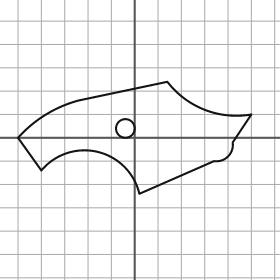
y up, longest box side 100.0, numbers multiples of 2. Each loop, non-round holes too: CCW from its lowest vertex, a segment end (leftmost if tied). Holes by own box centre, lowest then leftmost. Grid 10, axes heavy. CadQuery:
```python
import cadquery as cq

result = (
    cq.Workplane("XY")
    .moveTo(2.0, -24.0)
    .lineTo(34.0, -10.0)
    .threePointArc((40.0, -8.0), (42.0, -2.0))
    .lineTo(50.0, 10.0)
    .threePointArc((30.0, 12.0), (14.0, 24.0))
    .lineTo(-24.0, 16.0)
    .threePointArc((-38.0, 10.0), (-50.0, 0.0))
    .lineTo(-40.0, -14.0)
    .threePointArc((-16.0, -6.0), (2.0, -24.0))
    .close()
    .moveTo(-4.0, 4.0)
    .circle(4.0)
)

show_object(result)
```